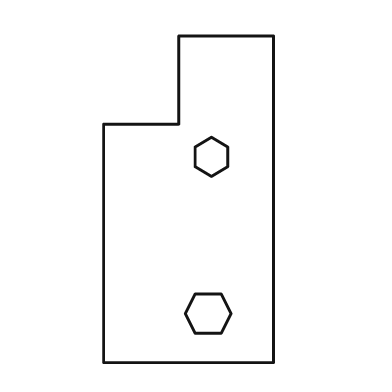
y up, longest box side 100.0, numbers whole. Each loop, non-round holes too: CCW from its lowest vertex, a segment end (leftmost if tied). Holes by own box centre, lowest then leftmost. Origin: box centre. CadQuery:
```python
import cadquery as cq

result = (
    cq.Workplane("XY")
    .moveTo(-26.0, -50.0)
    .lineTo(26.0, -50.0)
    .lineTo(26.0, 50.0)
    .lineTo(-3.0, 50.0)
    .lineTo(-3.0, 23.0)
    .lineTo(-26.0, 23.0)
    .close()
    .moveTo(2.0, -41.0)
    .lineTo(10.0, -41.0)
    .lineTo(13.0, -35.0)
    .lineTo(10.0, -29.0)
    .lineTo(2.0, -29.0)
    .lineTo(-1.0, -35.0)
    .close()
    .moveTo(7.0, 7.0)
    .lineTo(12.0, 10.0)
    .lineTo(12.0, 16.0)
    .lineTo(7.0, 19.0)
    .lineTo(2.0, 16.0)
    .lineTo(2.0, 10.0)
    .close()
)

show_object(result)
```